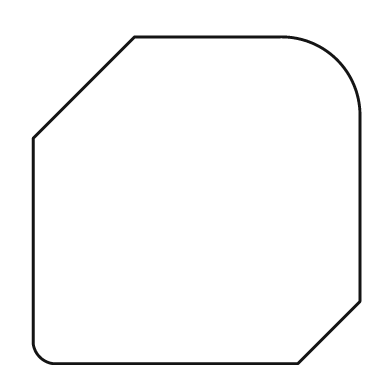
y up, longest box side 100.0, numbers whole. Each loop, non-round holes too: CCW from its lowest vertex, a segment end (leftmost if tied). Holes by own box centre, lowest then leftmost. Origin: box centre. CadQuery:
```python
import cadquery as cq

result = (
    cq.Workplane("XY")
    .moveTo(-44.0, -50.0)
    .lineTo(31.0, -50.0)
    .lineTo(50.0, -31.0)
    .lineTo(50.0, 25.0)
    .threePointArc((43.0, 43.0), (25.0, 50.0))
    .lineTo(-19.0, 50.0)
    .lineTo(-50.0, 19.0)
    .lineTo(-50.0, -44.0)
    .threePointArc((-48.0, -48.0), (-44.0, -50.0))
    .close()
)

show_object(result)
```